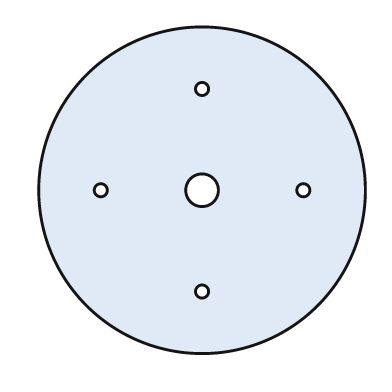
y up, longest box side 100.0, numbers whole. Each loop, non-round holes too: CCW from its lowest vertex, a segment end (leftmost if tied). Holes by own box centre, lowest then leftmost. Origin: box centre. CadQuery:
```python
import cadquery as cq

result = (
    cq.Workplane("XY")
    .moveTo(0.0, 0.0)
    .circle(50.0)
    .moveTo(0.0, -31.0)
    .circle(2.0)
    .moveTo(-31.0, 0.0)
    .circle(2.0)
    .moveTo(0.0, 0.0)
    .circle(5.0)
    .moveTo(31.0, 0.0)
    .circle(2.0)
    .moveTo(0.0, 31.0)
    .circle(2.0)
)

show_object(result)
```